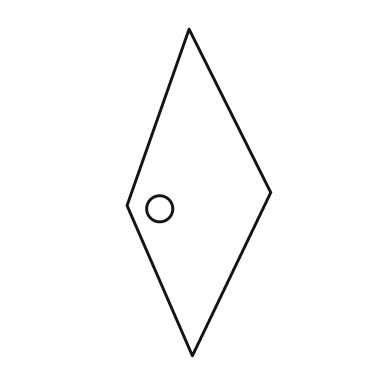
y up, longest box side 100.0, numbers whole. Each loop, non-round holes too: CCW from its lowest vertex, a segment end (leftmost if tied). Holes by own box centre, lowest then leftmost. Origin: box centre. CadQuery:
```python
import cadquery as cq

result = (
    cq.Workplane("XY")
    .moveTo(-2.0, -50.0)
    .lineTo(22.0, 0.0)
    .lineTo(-3.0, 50.0)
    .lineTo(-22.0, -4.0)
    .close()
    .moveTo(-12.0, -5.0)
    .circle(4.0)
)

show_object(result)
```